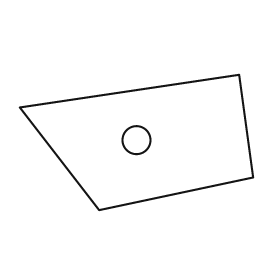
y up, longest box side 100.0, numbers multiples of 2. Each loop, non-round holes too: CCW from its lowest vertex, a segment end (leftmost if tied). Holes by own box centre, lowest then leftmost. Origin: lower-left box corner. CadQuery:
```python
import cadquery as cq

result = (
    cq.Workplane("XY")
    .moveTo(34.0, 0.0)
    .lineTo(100.0, 14.0)
    .lineTo(94.0, 58.0)
    .lineTo(0.0, 44.0)
    .close()
    .moveTo(50.0, 30.0)
    .circle(6.0)
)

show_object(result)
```